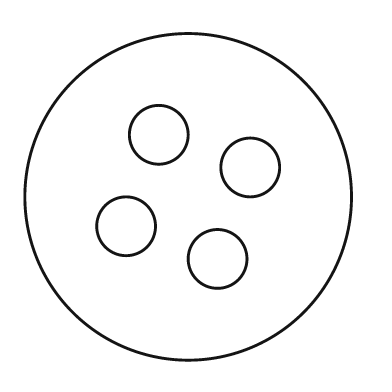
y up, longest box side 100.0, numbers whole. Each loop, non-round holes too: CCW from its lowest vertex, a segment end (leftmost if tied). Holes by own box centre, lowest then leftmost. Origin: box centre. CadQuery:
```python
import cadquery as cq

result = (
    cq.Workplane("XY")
    .moveTo(0.0, 0.0)
    .circle(50.0)
    .moveTo(9.0, -19.0)
    .circle(9.0)
    .moveTo(-19.0, -9.0)
    .circle(9.0)
    .moveTo(19.0, 9.0)
    .circle(9.0)
    .moveTo(-9.0, 19.0)
    .circle(9.0)
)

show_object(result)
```